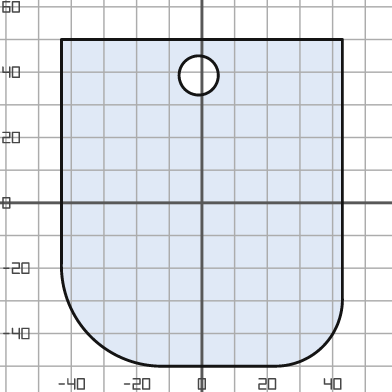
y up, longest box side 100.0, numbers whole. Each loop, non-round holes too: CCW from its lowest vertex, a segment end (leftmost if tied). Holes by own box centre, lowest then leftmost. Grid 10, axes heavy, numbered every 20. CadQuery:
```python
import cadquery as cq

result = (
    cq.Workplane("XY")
    .moveTo(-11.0, -50.0)
    .lineTo(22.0, -50.0)
    .threePointArc((37.0, -44.0), (43.0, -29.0))
    .lineTo(43.0, 50.0)
    .lineTo(-43.0, 50.0)
    .lineTo(-43.0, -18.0)
    .threePointArc((-34.0, -41.0), (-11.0, -50.0))
    .close()
    .moveTo(-1.0, 39.0)
    .circle(6.0)
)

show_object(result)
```